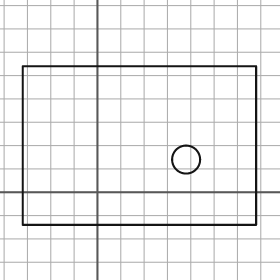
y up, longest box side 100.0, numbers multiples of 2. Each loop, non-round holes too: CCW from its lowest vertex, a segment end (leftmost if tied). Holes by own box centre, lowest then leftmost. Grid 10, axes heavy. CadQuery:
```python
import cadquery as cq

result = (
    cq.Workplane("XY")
    .moveTo(-32.0, -14.0)
    .lineTo(68.0, -14.0)
    .lineTo(68.0, 54.0)
    .lineTo(-32.0, 54.0)
    .close()
    .moveTo(38.0, 14.0)
    .circle(6.0)
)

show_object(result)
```